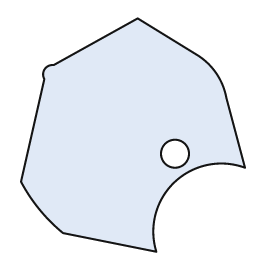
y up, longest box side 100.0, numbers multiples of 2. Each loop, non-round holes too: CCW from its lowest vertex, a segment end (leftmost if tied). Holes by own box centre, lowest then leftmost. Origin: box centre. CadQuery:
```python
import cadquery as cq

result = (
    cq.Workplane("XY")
    .moveTo(10.0, -50.0)
    .threePointArc((18.0, -20.0), (48.0, -14.0))
    .lineTo(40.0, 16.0)
    .threePointArc((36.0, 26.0), (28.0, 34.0))
    .lineTo(2.0, 50.0)
    .lineTo(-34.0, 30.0)
    .threePointArc((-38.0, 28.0), (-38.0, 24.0))
    .lineTo(-48.0, -20.0)
    .threePointArc((-40.0, -32.0), (-30.0, -42.0))
    .close()
    .moveTo(18.0, -8.0)
    .circle(6.0)
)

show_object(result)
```